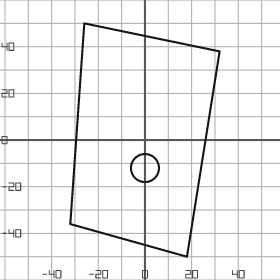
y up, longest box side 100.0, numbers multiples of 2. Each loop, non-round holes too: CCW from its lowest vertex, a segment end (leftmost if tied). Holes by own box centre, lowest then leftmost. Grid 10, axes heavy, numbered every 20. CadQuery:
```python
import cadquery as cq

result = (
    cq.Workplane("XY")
    .moveTo(18.0, -50.0)
    .lineTo(32.0, 38.0)
    .lineTo(-26.0, 50.0)
    .lineTo(-32.0, -36.0)
    .close()
    .moveTo(0.0, -12.0)
    .circle(6.0)
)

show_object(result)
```